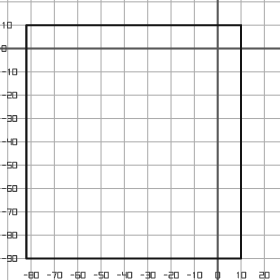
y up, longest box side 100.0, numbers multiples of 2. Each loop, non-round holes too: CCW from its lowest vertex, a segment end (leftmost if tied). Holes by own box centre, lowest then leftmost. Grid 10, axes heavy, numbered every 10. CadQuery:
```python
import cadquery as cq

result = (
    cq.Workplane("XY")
    .moveTo(-82.0, -90.0)
    .lineTo(10.0, -90.0)
    .lineTo(10.0, 10.0)
    .lineTo(-82.0, 10.0)
    .close()
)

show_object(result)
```